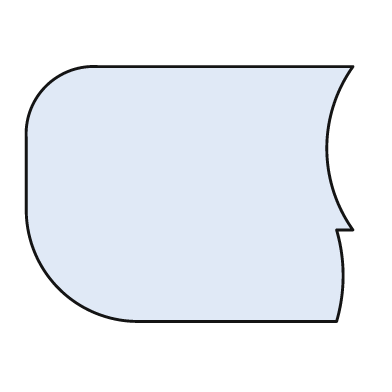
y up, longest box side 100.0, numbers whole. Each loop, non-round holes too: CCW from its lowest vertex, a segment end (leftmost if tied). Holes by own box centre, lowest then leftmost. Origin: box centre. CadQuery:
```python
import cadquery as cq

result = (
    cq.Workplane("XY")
    .moveTo(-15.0, -39.0)
    .lineTo(45.0, -39.0)
    .threePointArc((47.0, -25.0), (45.0, -11.0))
    .lineTo(50.0, -11.0)
    .threePointArc((42.0, 14.0), (50.0, 39.0))
    .lineTo(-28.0, 39.0)
    .threePointArc((-44.0, 33.0), (-50.0, 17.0))
    .lineTo(-50.0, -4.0)
    .threePointArc((-40.0, -29.0), (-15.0, -39.0))
    .close()
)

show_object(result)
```